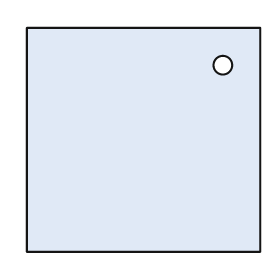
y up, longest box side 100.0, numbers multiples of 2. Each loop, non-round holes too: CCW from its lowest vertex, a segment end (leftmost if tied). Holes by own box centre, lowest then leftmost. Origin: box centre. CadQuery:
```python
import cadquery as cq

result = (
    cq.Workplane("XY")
    .moveTo(-50.0, -48.0)
    .lineTo(50.0, -48.0)
    .lineTo(50.0, 48.0)
    .lineTo(-50.0, 48.0)
    .close()
    .moveTo(34.0, 32.0)
    .circle(4.0)
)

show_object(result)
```